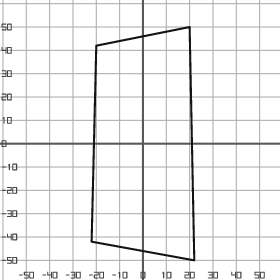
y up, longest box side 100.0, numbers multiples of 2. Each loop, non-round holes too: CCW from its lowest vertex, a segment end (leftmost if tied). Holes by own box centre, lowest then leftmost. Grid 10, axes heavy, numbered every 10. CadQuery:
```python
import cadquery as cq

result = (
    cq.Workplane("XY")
    .moveTo(22.0, -50.0)
    .lineTo(20.0, 50.0)
    .lineTo(-20.0, 42.0)
    .lineTo(-22.0, -42.0)
    .close()
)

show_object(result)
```